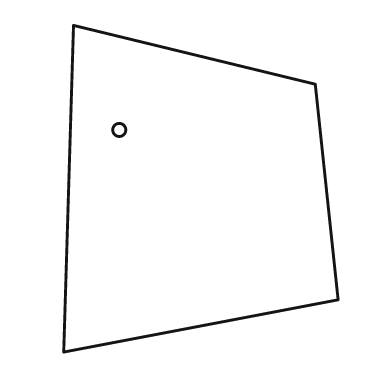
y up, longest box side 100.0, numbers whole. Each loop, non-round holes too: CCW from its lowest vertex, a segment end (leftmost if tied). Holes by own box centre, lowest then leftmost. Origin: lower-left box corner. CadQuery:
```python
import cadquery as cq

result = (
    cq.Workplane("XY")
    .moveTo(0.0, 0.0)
    .lineTo(84.0, 16.0)
    .lineTo(77.0, 82.0)
    .lineTo(3.0, 100.0)
    .close()
    .moveTo(17.0, 68.0)
    .circle(2.0)
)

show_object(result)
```